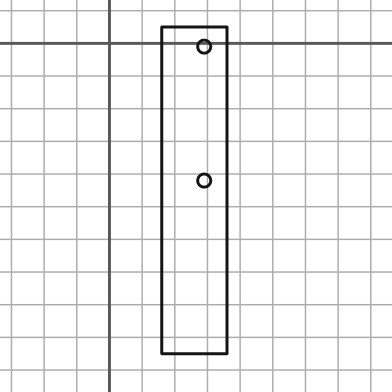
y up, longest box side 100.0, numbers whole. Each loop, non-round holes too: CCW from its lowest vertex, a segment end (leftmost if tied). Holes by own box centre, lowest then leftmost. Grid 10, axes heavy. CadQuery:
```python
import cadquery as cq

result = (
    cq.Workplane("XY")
    .moveTo(16.0, -95.0)
    .lineTo(36.0, -95.0)
    .lineTo(36.0, 5.0)
    .lineTo(16.0, 5.0)
    .close()
    .moveTo(29.0, -42.0)
    .circle(2.0)
    .moveTo(29.0, -1.0)
    .circle(2.0)
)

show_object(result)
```